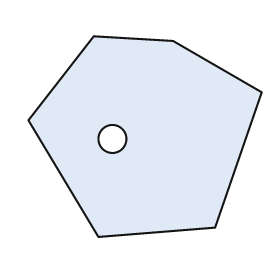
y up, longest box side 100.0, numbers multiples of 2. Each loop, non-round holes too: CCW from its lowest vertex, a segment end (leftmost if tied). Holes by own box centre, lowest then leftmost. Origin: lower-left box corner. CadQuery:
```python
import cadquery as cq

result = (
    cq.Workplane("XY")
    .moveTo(30.0, 0.0)
    .lineTo(80.0, 4.0)
    .lineTo(100.0, 62.0)
    .lineTo(62.0, 84.0)
    .lineTo(28.0, 86.0)
    .lineTo(0.0, 50.0)
    .close()
    .moveTo(36.0, 42.0)
    .circle(6.0)
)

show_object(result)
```